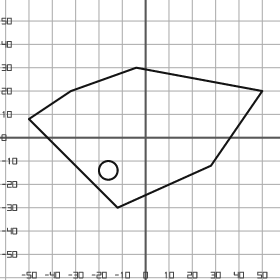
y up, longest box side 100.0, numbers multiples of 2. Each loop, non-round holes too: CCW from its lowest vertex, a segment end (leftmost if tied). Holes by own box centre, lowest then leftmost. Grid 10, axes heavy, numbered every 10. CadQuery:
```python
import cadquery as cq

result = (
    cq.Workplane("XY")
    .moveTo(-12.0, -30.0)
    .lineTo(28.0, -12.0)
    .lineTo(50.0, 20.0)
    .lineTo(-4.0, 30.0)
    .lineTo(-32.0, 20.0)
    .lineTo(-50.0, 8.0)
    .close()
    .moveTo(-16.0, -14.0)
    .circle(4.0)
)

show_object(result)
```